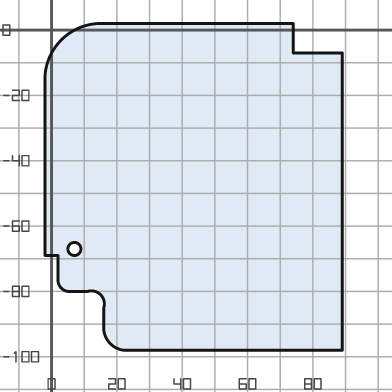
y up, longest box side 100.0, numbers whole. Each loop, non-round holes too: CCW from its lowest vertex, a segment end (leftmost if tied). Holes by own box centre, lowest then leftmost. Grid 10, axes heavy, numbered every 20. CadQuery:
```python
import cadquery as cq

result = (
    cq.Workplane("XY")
    .moveTo(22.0, -98.0)
    .lineTo(89.0, -98.0)
    .lineTo(89.0, -7.0)
    .lineTo(74.0, -7.0)
    .lineTo(74.0, 2.0)
    .lineTo(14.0, 2.0)
    .threePointArc((3.0, -3.0), (-2.0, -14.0))
    .lineTo(-2.0, -69.0)
    .lineTo(2.0, -69.0)
    .lineTo(2.0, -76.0)
    .threePointArc((3.0, -79.0), (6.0, -80.0))
    .lineTo(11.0, -80.0)
    .threePointArc((15.0, -81.0), (16.0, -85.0))
    .lineTo(16.0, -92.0)
    .threePointArc((18.0, -96.0), (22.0, -98.0))
    .close()
    .moveTo(7.0, -67.0)
    .circle(2.0)
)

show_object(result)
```